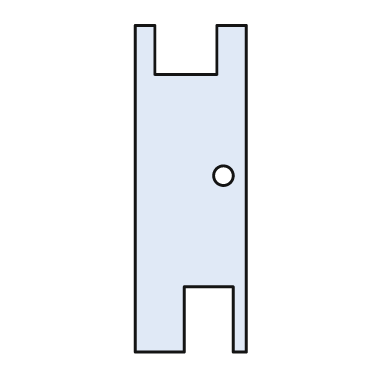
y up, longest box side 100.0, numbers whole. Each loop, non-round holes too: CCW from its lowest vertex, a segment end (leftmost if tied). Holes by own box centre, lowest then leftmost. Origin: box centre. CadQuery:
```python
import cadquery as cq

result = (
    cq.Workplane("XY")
    .moveTo(-17.0, -50.0)
    .lineTo(-2.0, -50.0)
    .lineTo(-2.0, -30.0)
    .lineTo(13.0, -30.0)
    .lineTo(13.0, -50.0)
    .lineTo(17.0, -50.0)
    .lineTo(17.0, 50.0)
    .lineTo(8.0, 50.0)
    .lineTo(8.0, 35.0)
    .lineTo(-11.0, 35.0)
    .lineTo(-11.0, 50.0)
    .lineTo(-17.0, 50.0)
    .close()
    .moveTo(10.0, 4.0)
    .circle(3.0)
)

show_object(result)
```